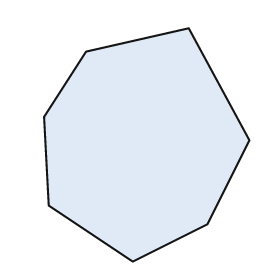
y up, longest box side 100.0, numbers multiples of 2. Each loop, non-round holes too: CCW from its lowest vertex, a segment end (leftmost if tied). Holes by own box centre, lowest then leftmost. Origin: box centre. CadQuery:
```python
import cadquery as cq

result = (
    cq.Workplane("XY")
    .moveTo(-6.0, -50.0)
    .lineTo(26.0, -34.0)
    .lineTo(44.0, 2.0)
    .lineTo(18.0, 50.0)
    .lineTo(-26.0, 40.0)
    .lineTo(-44.0, 12.0)
    .lineTo(-42.0, -26.0)
    .close()
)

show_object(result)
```